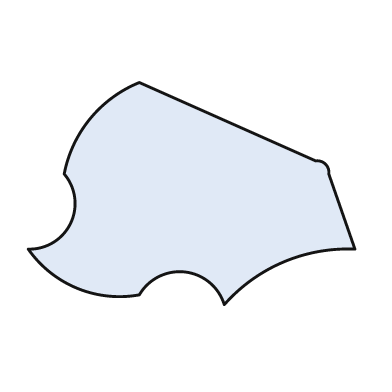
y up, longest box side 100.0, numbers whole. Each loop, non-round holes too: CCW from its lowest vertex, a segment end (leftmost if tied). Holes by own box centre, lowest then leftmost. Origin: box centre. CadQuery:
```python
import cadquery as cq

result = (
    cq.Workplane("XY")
    .moveTo(10.0, -34.0)
    .threePointArc((28.0, -21.0), (50.0, -17.0))
    .lineTo(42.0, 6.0)
    .threePointArc((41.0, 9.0), (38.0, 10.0))
    .lineTo(-16.0, 34.0)
    .threePointArc((-31.0, 23.0), (-39.0, 6.0))
    .threePointArc((-37.0, -9.0), (-50.0, -17.0))
    .threePointArc((-35.0, -29.0), (-16.0, -31.0))
    .threePointArc((-2.0, -24.0), (10.0, -34.0))
    .close()
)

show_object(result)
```